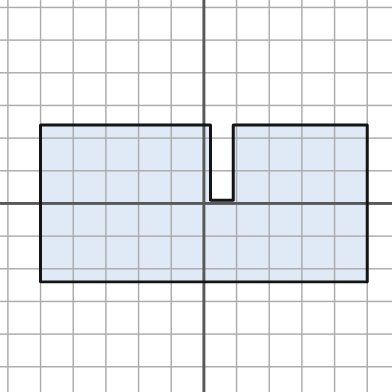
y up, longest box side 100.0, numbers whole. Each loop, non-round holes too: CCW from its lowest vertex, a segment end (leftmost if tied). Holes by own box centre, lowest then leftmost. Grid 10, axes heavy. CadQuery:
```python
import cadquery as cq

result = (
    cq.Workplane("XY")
    .moveTo(-50.0, -24.0)
    .lineTo(50.0, -24.0)
    .lineTo(50.0, 24.0)
    .lineTo(9.0, 24.0)
    .lineTo(9.0, 1.0)
    .lineTo(2.0, 1.0)
    .lineTo(2.0, 24.0)
    .lineTo(-50.0, 24.0)
    .close()
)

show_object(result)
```